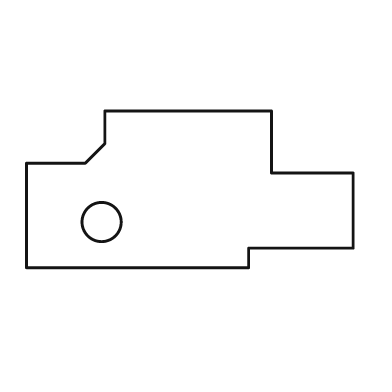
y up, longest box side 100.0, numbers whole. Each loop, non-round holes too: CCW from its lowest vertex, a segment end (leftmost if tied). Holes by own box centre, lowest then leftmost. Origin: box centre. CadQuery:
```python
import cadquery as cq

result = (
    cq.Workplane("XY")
    .moveTo(-50.0, -24.0)
    .lineTo(18.0, -24.0)
    .lineTo(18.0, -18.0)
    .lineTo(50.0, -18.0)
    .lineTo(50.0, 5.0)
    .lineTo(25.0, 5.0)
    .lineTo(25.0, 24.0)
    .lineTo(-26.0, 24.0)
    .lineTo(-26.0, 14.0)
    .lineTo(-32.0, 8.0)
    .lineTo(-50.0, 8.0)
    .close()
    .moveTo(-27.0, -10.0)
    .circle(6.0)
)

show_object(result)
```